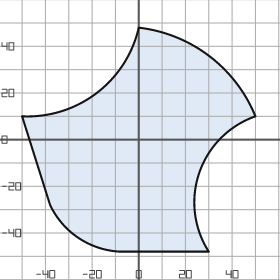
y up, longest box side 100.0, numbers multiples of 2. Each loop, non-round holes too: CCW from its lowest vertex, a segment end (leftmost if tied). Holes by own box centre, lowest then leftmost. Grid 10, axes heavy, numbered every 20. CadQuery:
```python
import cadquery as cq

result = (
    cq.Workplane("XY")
    .moveTo(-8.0, -48.0)
    .lineTo(30.0, -48.0)
    .threePointArc((26.0, -14.0), (50.0, 10.0))
    .threePointArc((30.0, 36.0), (0.0, 48.0))
    .threePointArc((-18.0, 20.0), (-50.0, 10.0))
    .lineTo(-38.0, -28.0)
    .threePointArc((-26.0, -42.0), (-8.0, -48.0))
    .close()
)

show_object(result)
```